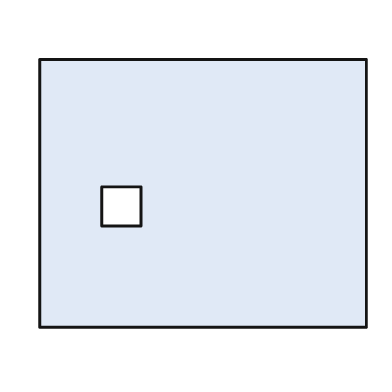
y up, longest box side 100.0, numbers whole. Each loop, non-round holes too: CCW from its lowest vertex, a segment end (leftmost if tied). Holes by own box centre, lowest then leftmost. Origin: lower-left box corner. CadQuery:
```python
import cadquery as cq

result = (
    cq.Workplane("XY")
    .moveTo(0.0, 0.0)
    .lineTo(100.0, 0.0)
    .lineTo(100.0, 82.0)
    .lineTo(0.0, 82.0)
    .close()
    .moveTo(19.0, 31.0)
    .lineTo(31.0, 31.0)
    .lineTo(31.0, 43.0)
    .lineTo(19.0, 43.0)
    .close()
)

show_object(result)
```